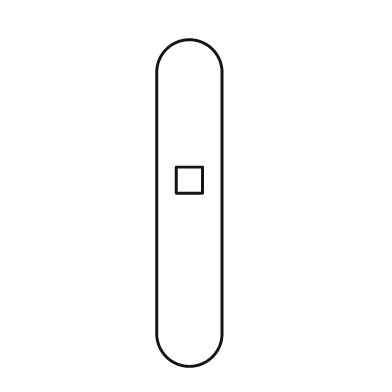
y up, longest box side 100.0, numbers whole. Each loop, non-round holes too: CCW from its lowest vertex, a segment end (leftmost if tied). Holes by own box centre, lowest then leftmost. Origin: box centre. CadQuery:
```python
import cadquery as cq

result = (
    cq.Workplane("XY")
    .moveTo(-10.0, -40.0)
    .threePointArc((0.0, -50.0), (10.0, -40.0))
    .lineTo(10.0, 40.0)
    .threePointArc((0.0, 50.0), (-10.0, 40.0))
    .close()
    .moveTo(-4.0, 3.0)
    .lineTo(4.0, 3.0)
    .lineTo(4.0, 11.0)
    .lineTo(-4.0, 11.0)
    .close()
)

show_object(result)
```